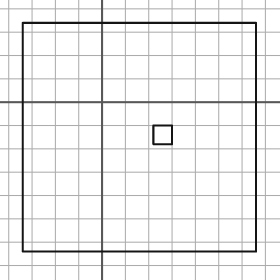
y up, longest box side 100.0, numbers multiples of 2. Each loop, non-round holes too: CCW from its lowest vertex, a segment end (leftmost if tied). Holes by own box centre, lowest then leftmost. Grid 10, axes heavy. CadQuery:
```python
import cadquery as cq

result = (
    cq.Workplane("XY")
    .moveTo(-34.0, -64.0)
    .lineTo(66.0, -64.0)
    .lineTo(66.0, 34.0)
    .lineTo(-34.0, 34.0)
    .close()
    .moveTo(22.0, -18.0)
    .lineTo(30.0, -18.0)
    .lineTo(30.0, -10.0)
    .lineTo(22.0, -10.0)
    .close()
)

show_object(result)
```